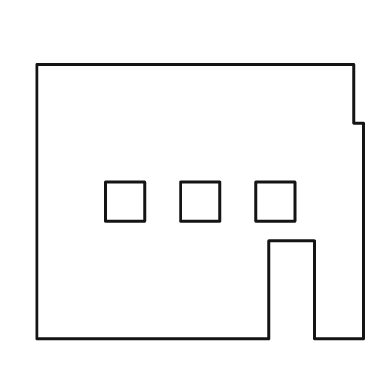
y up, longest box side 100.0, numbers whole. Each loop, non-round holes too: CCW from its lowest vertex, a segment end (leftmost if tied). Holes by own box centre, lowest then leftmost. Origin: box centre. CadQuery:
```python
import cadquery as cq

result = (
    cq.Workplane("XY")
    .moveTo(-50.0, -42.0)
    .lineTo(21.0, -42.0)
    .lineTo(21.0, -12.0)
    .lineTo(35.0, -12.0)
    .lineTo(35.0, -42.0)
    .lineTo(50.0, -42.0)
    .lineTo(50.0, 24.0)
    .lineTo(47.0, 24.0)
    .lineTo(47.0, 42.0)
    .lineTo(-50.0, 42.0)
    .close()
    .moveTo(-29.0, -6.0)
    .lineTo(-17.0, -6.0)
    .lineTo(-17.0, 6.0)
    .lineTo(-29.0, 6.0)
    .close()
    .moveTo(-6.0, -6.0)
    .lineTo(6.0, -6.0)
    .lineTo(6.0, 6.0)
    .lineTo(-6.0, 6.0)
    .close()
    .moveTo(17.0, -6.0)
    .lineTo(29.0, -6.0)
    .lineTo(29.0, 6.0)
    .lineTo(17.0, 6.0)
    .close()
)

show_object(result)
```